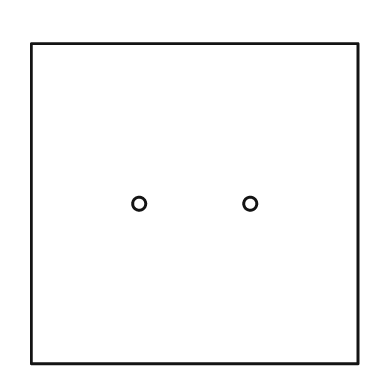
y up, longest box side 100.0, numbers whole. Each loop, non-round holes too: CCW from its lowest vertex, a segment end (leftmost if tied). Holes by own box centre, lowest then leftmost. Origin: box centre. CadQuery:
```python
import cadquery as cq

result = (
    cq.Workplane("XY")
    .moveTo(-50.0, -49.0)
    .lineTo(50.0, -49.0)
    .lineTo(50.0, 49.0)
    .lineTo(-50.0, 49.0)
    .close()
    .moveTo(-17.0, 0.0)
    .circle(2.0)
    .moveTo(17.0, 0.0)
    .circle(2.0)
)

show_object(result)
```